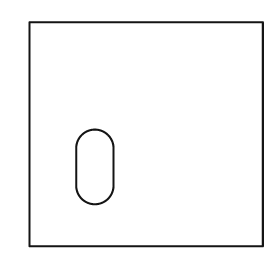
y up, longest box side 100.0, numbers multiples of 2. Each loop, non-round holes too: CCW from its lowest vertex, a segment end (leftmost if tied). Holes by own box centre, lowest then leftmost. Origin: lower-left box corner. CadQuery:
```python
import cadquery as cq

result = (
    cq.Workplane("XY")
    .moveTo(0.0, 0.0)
    .lineTo(100.0, 0.0)
    .lineTo(100.0, 96.0)
    .lineTo(0.0, 96.0)
    .close()
    .moveTo(20.0, 26.0)
    .threePointArc((28.0, 18.0), (36.0, 26.0))
    .lineTo(36.0, 42.0)
    .threePointArc((28.0, 50.0), (20.0, 42.0))
    .close()
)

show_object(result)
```